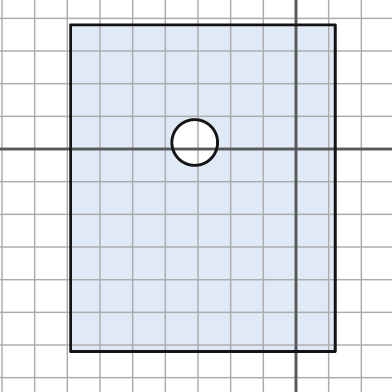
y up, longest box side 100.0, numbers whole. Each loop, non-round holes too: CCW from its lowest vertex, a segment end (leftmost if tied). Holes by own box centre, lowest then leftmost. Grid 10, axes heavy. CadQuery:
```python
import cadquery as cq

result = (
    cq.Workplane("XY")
    .moveTo(-69.0, -62.0)
    .lineTo(12.0, -62.0)
    .lineTo(12.0, 38.0)
    .lineTo(-69.0, 38.0)
    .close()
    .moveTo(-31.0, 2.0)
    .circle(7.0)
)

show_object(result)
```